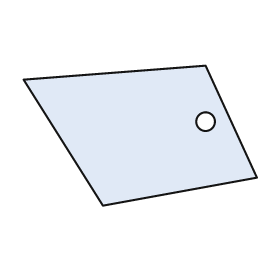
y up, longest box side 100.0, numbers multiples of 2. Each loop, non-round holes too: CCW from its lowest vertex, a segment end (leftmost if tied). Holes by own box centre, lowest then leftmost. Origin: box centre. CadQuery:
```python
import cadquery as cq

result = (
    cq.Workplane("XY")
    .moveTo(-16.0, -30.0)
    .lineTo(50.0, -18.0)
    .lineTo(28.0, 30.0)
    .lineTo(-50.0, 24.0)
    .close()
    .moveTo(28.0, 6.0)
    .circle(4.0)
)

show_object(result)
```